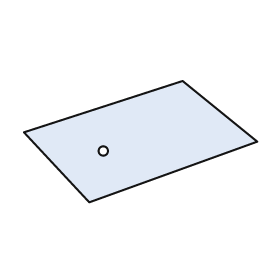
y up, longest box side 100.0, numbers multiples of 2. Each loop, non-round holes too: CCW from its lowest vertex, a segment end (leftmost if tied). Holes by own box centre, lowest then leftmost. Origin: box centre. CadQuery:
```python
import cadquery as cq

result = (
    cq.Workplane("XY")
    .moveTo(-22.0, -26.0)
    .lineTo(50.0, 0.0)
    .lineTo(18.0, 26.0)
    .lineTo(-50.0, 4.0)
    .close()
    .moveTo(-16.0, -4.0)
    .circle(2.0)
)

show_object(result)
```